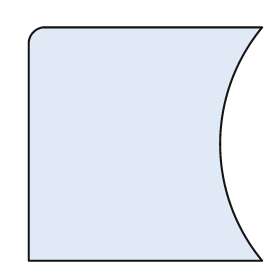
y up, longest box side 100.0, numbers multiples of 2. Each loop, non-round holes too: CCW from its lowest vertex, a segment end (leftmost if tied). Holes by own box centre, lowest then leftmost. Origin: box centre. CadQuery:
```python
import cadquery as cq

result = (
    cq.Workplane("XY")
    .moveTo(-50.0, -50.0)
    .lineTo(50.0, -50.0)
    .threePointArc((32.0, 0.0), (50.0, 50.0))
    .lineTo(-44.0, 50.0)
    .threePointArc((-48.0, 48.0), (-50.0, 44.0))
    .close()
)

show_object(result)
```